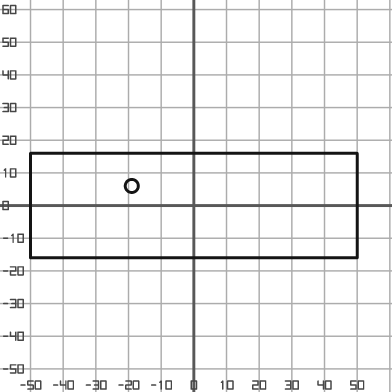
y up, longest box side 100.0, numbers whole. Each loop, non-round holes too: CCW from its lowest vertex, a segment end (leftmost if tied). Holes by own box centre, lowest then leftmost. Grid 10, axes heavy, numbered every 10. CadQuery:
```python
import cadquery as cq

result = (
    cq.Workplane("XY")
    .moveTo(-50.0, -16.0)
    .lineTo(50.0, -16.0)
    .lineTo(50.0, 16.0)
    .lineTo(-50.0, 16.0)
    .close()
    .moveTo(-19.0, 6.0)
    .circle(2.0)
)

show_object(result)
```